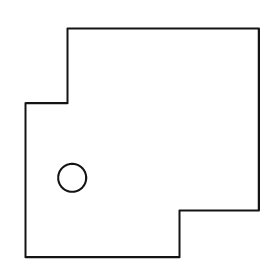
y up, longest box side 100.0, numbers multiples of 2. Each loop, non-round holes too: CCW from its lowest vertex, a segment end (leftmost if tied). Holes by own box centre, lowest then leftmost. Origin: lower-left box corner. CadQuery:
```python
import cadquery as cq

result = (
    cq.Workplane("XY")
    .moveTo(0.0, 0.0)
    .lineTo(66.0, 0.0)
    .lineTo(66.0, 20.0)
    .lineTo(100.0, 20.0)
    .lineTo(100.0, 98.0)
    .lineTo(18.0, 98.0)
    .lineTo(18.0, 66.0)
    .lineTo(0.0, 66.0)
    .close()
    .moveTo(20.0, 34.0)
    .circle(6.0)
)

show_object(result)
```